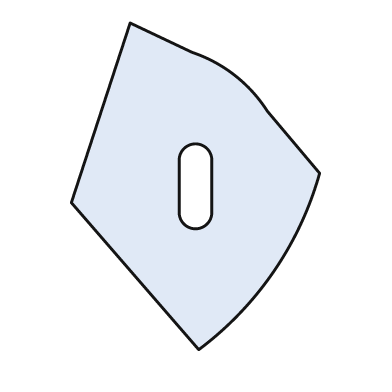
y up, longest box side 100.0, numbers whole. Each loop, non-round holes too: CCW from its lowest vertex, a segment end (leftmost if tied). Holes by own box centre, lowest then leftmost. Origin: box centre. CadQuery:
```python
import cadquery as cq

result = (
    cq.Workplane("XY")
    .moveTo(1.0, -50.0)
    .threePointArc((24.0, -26.0), (38.0, 4.0))
    .lineTo(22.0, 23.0)
    .threePointArc((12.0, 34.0), (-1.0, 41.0))
    .lineTo(-20.0, 50.0)
    .lineTo(-38.0, -5.0)
    .close()
    .moveTo(-5.0, -8.0)
    .threePointArc((0.0, -13.0), (5.0, -8.0))
    .lineTo(5.0, 8.0)
    .threePointArc((0.0, 13.0), (-5.0, 8.0))
    .close()
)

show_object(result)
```